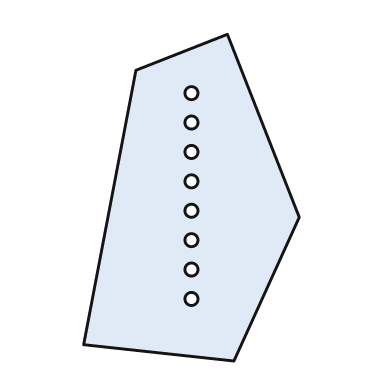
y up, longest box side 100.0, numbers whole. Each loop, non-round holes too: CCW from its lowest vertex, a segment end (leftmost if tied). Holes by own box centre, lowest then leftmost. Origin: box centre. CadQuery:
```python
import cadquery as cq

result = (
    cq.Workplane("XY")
    .moveTo(13.0, -50.0)
    .lineTo(33.0, -6.0)
    .lineTo(11.0, 50.0)
    .lineTo(-17.0, 39.0)
    .lineTo(-33.0, -45.0)
    .close()
    .moveTo(0.0, -31.0)
    .circle(2.0)
    .moveTo(0.0, -22.0)
    .circle(2.0)
    .moveTo(0.0, -13.0)
    .circle(2.0)
    .moveTo(0.0, -4.0)
    .circle(2.0)
    .moveTo(0.0, 5.0)
    .circle(2.0)
    .moveTo(0.0, 14.0)
    .circle(2.0)
    .moveTo(0.0, 23.0)
    .circle(2.0)
    .moveTo(0.0, 32.0)
    .circle(2.0)
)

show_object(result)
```